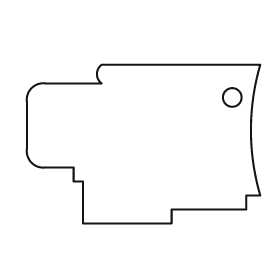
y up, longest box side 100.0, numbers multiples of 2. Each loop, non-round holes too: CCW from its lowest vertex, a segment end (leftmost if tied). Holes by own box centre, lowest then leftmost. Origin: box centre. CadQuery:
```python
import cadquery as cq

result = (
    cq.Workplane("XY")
    .moveTo(-26.0, -34.0)
    .lineTo(12.0, -34.0)
    .lineTo(12.0, -28.0)
    .lineTo(44.0, -28.0)
    .lineTo(44.0, -22.0)
    .lineTo(50.0, -22.0)
    .threePointArc((46.0, 6.0), (50.0, 34.0))
    .lineTo(-18.0, 34.0)
    .threePointArc((-20.0, 30.0), (-18.0, 26.0))
    .lineTo(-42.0, 26.0)
    .threePointArc((-48.0, 24.0), (-50.0, 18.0))
    .lineTo(-50.0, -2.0)
    .threePointArc((-48.0, -8.0), (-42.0, -10.0))
    .lineTo(-30.0, -10.0)
    .lineTo(-30.0, -16.0)
    .lineTo(-26.0, -16.0)
    .close()
    .moveTo(38.0, 20.0)
    .circle(4.0)
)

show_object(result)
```